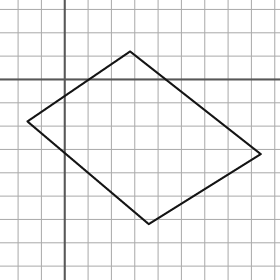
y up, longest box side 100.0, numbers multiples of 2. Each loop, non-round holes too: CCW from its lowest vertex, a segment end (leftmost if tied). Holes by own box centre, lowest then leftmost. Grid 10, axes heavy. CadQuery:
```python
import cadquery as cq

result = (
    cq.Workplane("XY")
    .moveTo(36.0, -62.0)
    .lineTo(84.0, -32.0)
    .lineTo(28.0, 12.0)
    .lineTo(-16.0, -18.0)
    .close()
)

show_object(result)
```